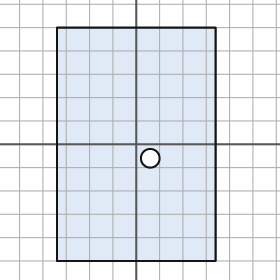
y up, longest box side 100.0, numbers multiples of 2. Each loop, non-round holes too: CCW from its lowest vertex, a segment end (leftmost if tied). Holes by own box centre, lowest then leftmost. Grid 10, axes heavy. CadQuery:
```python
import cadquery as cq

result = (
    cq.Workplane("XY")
    .moveTo(-34.0, -50.0)
    .lineTo(34.0, -50.0)
    .lineTo(34.0, 50.0)
    .lineTo(-34.0, 50.0)
    .close()
    .moveTo(6.0, -6.0)
    .circle(4.0)
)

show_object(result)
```